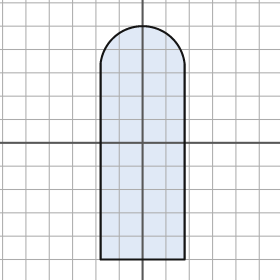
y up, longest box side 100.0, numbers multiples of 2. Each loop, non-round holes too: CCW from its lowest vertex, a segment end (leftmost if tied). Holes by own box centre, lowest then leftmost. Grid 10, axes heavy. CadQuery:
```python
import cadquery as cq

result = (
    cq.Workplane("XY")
    .moveTo(-18.0, -50.0)
    .lineTo(18.0, -50.0)
    .lineTo(18.0, 34.0)
    .threePointArc((0.0, 50.0), (-18.0, 34.0))
    .close()
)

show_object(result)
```